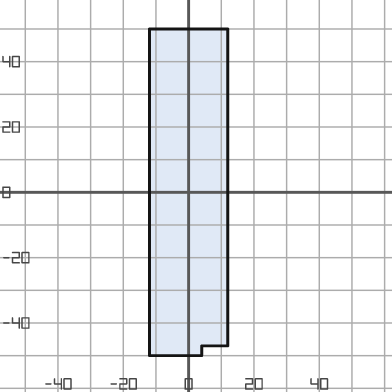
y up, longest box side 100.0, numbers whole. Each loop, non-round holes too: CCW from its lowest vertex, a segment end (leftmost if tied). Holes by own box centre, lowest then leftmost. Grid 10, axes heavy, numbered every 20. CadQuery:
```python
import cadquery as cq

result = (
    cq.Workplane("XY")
    .moveTo(-12.0, -50.0)
    .lineTo(4.0, -50.0)
    .lineTo(4.0, -47.0)
    .lineTo(12.0, -47.0)
    .lineTo(12.0, 50.0)
    .lineTo(-12.0, 50.0)
    .close()
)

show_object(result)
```